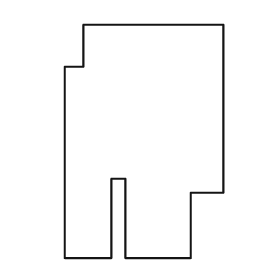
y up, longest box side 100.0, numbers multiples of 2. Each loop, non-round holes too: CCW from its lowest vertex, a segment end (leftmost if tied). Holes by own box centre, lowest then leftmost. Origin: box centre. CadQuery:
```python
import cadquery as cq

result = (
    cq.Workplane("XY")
    .moveTo(-34.0, -50.0)
    .lineTo(-14.0, -50.0)
    .lineTo(-14.0, -16.0)
    .lineTo(-8.0, -16.0)
    .lineTo(-8.0, -50.0)
    .lineTo(20.0, -50.0)
    .lineTo(20.0, -22.0)
    .lineTo(34.0, -22.0)
    .lineTo(34.0, 50.0)
    .lineTo(-26.0, 50.0)
    .lineTo(-26.0, 32.0)
    .lineTo(-34.0, 32.0)
    .close()
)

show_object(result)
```